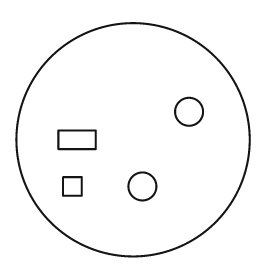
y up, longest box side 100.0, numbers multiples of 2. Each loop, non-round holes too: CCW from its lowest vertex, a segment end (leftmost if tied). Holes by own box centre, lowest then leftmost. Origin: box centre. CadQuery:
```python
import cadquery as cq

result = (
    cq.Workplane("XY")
    .moveTo(0.0, 0.0)
    .circle(50.0)
    .moveTo(-30.0, -24.0)
    .lineTo(-22.0, -24.0)
    .lineTo(-22.0, -16.0)
    .lineTo(-30.0, -16.0)
    .close()
    .moveTo(4.0, -20.0)
    .circle(6.0)
    .moveTo(-32.0, -4.0)
    .lineTo(-16.0, -4.0)
    .lineTo(-16.0, 4.0)
    .lineTo(-32.0, 4.0)
    .close()
    .moveTo(24.0, 12.0)
    .circle(6.0)
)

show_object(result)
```